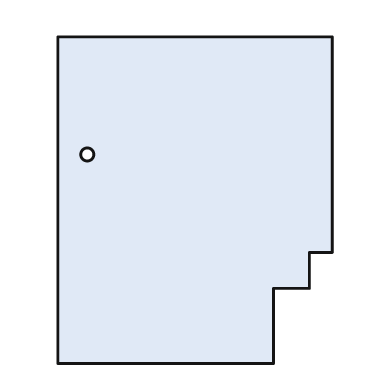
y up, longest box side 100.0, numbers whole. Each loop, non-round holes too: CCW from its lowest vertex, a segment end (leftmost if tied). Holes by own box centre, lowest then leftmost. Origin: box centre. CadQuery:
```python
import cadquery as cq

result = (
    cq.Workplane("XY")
    .moveTo(-42.0, -50.0)
    .lineTo(24.0, -50.0)
    .lineTo(24.0, -27.0)
    .lineTo(35.0, -27.0)
    .lineTo(35.0, -16.0)
    .lineTo(42.0, -16.0)
    .lineTo(42.0, 50.0)
    .lineTo(-42.0, 50.0)
    .close()
    .moveTo(-33.0, 14.0)
    .circle(2.0)
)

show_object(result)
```